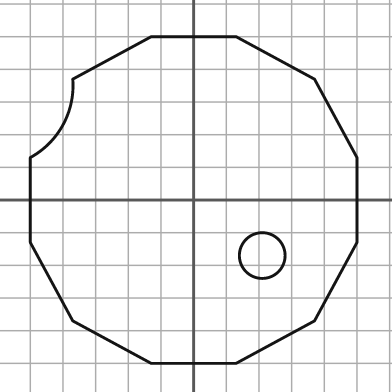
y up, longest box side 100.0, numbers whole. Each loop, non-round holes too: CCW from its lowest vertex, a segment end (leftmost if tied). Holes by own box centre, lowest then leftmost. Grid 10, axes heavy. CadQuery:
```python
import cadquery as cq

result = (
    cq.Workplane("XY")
    .moveTo(-13.0, -50.0)
    .lineTo(13.0, -50.0)
    .lineTo(37.0, -37.0)
    .lineTo(50.0, -13.0)
    .lineTo(50.0, 13.0)
    .lineTo(37.0, 37.0)
    .lineTo(13.0, 50.0)
    .lineTo(-13.0, 50.0)
    .lineTo(-37.0, 37.0)
    .threePointArc((-40.0, 23.0), (-50.0, 13.0))
    .lineTo(-50.0, -13.0)
    .lineTo(-37.0, -37.0)
    .close()
    .moveTo(21.0, -17.0)
    .circle(7.0)
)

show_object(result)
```